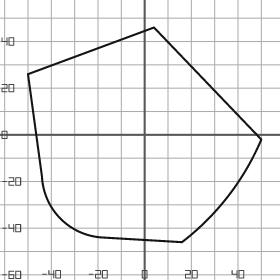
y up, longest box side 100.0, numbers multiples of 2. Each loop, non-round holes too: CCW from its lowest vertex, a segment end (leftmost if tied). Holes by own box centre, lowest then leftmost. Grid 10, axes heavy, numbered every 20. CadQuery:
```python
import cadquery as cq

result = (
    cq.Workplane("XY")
    .moveTo(16.0, -46.0)
    .threePointArc((36.0, -26.0), (50.0, -2.0))
    .lineTo(4.0, 46.0)
    .lineTo(-50.0, 26.0)
    .lineTo(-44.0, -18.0)
    .threePointArc((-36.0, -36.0), (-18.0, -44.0))
    .close()
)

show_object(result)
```